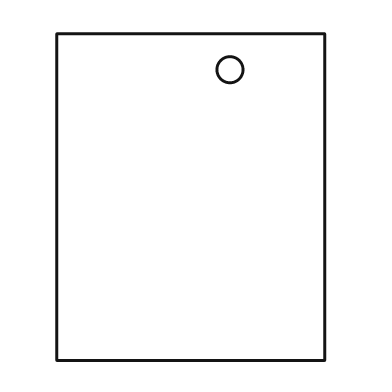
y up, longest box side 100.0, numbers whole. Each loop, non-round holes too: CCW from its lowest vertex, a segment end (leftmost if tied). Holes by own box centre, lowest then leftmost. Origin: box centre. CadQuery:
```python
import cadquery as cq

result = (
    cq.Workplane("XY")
    .moveTo(-41.0, -50.0)
    .lineTo(41.0, -50.0)
    .lineTo(41.0, 50.0)
    .lineTo(-41.0, 50.0)
    .close()
    .moveTo(12.0, 39.0)
    .circle(4.0)
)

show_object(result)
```